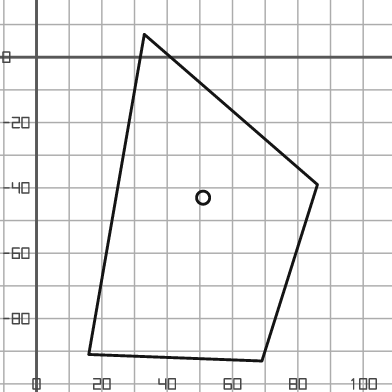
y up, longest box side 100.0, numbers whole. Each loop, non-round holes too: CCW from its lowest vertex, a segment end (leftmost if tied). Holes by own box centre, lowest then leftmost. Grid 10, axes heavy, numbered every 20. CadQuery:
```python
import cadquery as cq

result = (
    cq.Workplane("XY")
    .moveTo(69.0, -93.0)
    .lineTo(86.0, -39.0)
    .lineTo(33.0, 7.0)
    .lineTo(16.0, -91.0)
    .close()
    .moveTo(51.0, -43.0)
    .circle(2.0)
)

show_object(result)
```